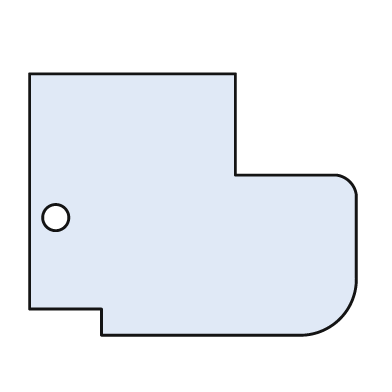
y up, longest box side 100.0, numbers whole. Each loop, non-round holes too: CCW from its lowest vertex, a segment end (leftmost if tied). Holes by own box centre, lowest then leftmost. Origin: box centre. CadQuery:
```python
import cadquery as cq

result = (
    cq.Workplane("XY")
    .moveTo(-28.0, -40.0)
    .lineTo(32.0, -40.0)
    .threePointArc((45.0, -35.0), (50.0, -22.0))
    .lineTo(50.0, 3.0)
    .threePointArc((48.0, 7.0), (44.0, 9.0))
    .lineTo(13.0, 9.0)
    .lineTo(13.0, 40.0)
    .lineTo(-50.0, 40.0)
    .lineTo(-50.0, -32.0)
    .lineTo(-28.0, -32.0)
    .close()
    .moveTo(-42.0, -4.0)
    .circle(4.0)
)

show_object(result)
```